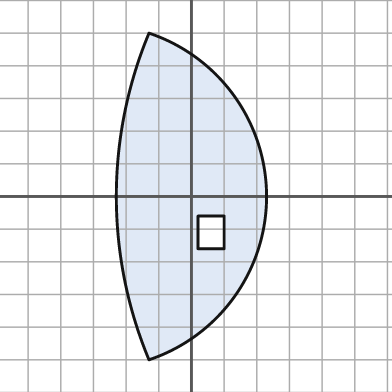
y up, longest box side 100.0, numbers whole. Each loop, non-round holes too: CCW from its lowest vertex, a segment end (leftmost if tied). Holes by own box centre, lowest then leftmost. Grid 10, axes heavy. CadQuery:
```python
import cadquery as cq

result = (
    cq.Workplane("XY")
    .moveTo(-13.0, -50.0)
    .threePointArc((23.0, 0.0), (-13.0, 50.0))
    .threePointArc((-23.0, 0.0), (-13.0, -50.0))
    .close()
    .moveTo(2.0, -16.0)
    .lineTo(10.0, -16.0)
    .lineTo(10.0, -6.0)
    .lineTo(2.0, -6.0)
    .close()
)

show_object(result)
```